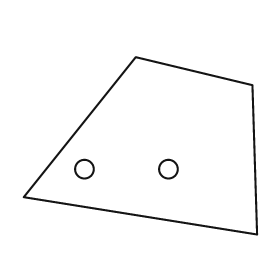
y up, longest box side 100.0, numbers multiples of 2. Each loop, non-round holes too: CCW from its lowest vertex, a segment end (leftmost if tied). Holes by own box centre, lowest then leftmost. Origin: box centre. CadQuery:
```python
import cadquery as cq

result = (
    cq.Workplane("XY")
    .moveTo(50.0, -38.0)
    .lineTo(48.0, 26.0)
    .lineTo(-2.0, 38.0)
    .lineTo(-50.0, -22.0)
    .close()
    .moveTo(-24.0, -10.0)
    .circle(4.0)
    .moveTo(12.0, -10.0)
    .circle(4.0)
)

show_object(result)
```